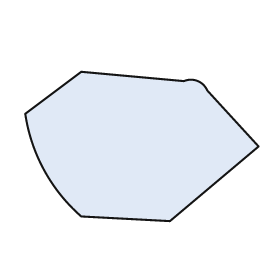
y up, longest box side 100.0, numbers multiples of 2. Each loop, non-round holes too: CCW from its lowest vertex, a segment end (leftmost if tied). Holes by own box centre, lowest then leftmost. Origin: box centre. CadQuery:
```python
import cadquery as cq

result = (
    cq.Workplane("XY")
    .moveTo(12.0, -32.0)
    .lineTo(50.0, 0.0)
    .lineTo(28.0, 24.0)
    .threePointArc((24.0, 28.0), (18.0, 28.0))
    .lineTo(-26.0, 32.0)
    .lineTo(-50.0, 14.0)
    .threePointArc((-42.0, -10.0), (-26.0, -30.0))
    .close()
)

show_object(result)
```